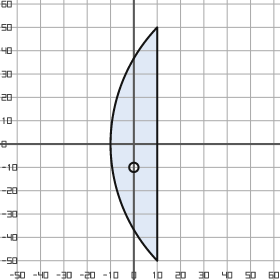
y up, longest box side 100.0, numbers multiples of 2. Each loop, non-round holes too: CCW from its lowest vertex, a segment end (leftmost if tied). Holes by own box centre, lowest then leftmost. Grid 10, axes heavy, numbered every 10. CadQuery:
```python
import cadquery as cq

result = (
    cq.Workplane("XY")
    .moveTo(10.0, -50.0)
    .lineTo(10.0, 50.0)
    .threePointArc((-10.0, 0.0), (10.0, -50.0))
    .close()
    .moveTo(0.0, -10.0)
    .circle(2.0)
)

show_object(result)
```